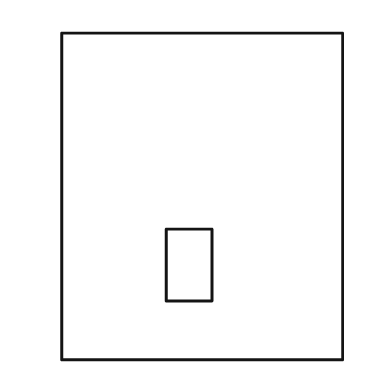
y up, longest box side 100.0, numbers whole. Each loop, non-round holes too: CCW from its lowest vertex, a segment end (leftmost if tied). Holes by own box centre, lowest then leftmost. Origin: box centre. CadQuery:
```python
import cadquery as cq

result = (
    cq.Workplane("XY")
    .moveTo(-43.0, -50.0)
    .lineTo(43.0, -50.0)
    .lineTo(43.0, 50.0)
    .lineTo(-43.0, 50.0)
    .close()
    .moveTo(-11.0, -32.0)
    .lineTo(3.0, -32.0)
    .lineTo(3.0, -10.0)
    .lineTo(-11.0, -10.0)
    .close()
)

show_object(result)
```